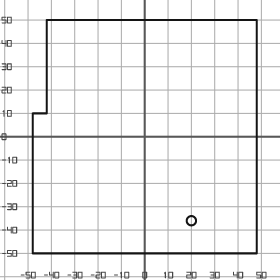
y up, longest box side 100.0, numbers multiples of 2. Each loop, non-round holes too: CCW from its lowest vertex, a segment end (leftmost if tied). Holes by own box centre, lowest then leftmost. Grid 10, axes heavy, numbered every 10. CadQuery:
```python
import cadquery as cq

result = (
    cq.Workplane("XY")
    .moveTo(-48.0, -50.0)
    .lineTo(48.0, -50.0)
    .lineTo(48.0, 50.0)
    .lineTo(-42.0, 50.0)
    .lineTo(-42.0, 10.0)
    .lineTo(-48.0, 10.0)
    .close()
    .moveTo(20.0, -36.0)
    .circle(2.0)
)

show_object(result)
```